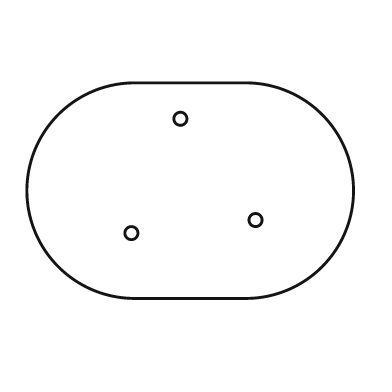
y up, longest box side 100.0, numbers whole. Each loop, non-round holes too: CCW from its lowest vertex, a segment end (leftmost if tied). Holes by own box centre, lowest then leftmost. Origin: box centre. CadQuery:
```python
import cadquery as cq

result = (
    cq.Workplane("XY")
    .moveTo(-17.0, -33.0)
    .lineTo(17.0, -33.0)
    .threePointArc((50.0, 0.0), (17.0, 33.0))
    .lineTo(-17.0, 33.0)
    .threePointArc((-50.0, 0.0), (-17.0, -33.0))
    .close()
    .moveTo(-18.0, -13.0)
    .circle(2.0)
    .moveTo(20.0, -9.0)
    .circle(2.0)
    .moveTo(-3.0, 22.0)
    .circle(2.0)
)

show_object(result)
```